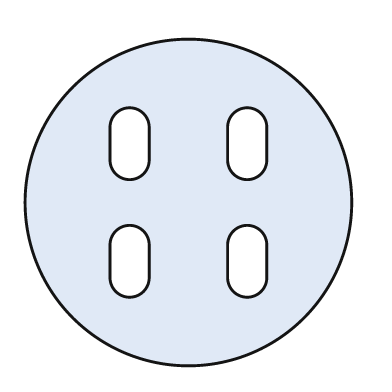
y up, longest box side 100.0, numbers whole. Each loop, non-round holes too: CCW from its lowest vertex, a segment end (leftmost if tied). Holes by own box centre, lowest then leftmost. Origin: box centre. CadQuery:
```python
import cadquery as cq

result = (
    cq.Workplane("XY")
    .moveTo(0.0, 0.0)
    .circle(50.0)
    .moveTo(-24.0, -23.0)
    .threePointArc((-18.0, -29.0), (-12.0, -23.0))
    .lineTo(-12.0, -13.0)
    .threePointArc((-18.0, -7.0), (-24.0, -13.0))
    .close()
    .moveTo(12.0, -23.0)
    .threePointArc((18.0, -29.0), (24.0, -23.0))
    .lineTo(24.0, -13.0)
    .threePointArc((18.0, -7.0), (12.0, -13.0))
    .close()
    .moveTo(-24.0, 13.0)
    .threePointArc((-18.0, 7.0), (-12.0, 13.0))
    .lineTo(-12.0, 23.0)
    .threePointArc((-18.0, 29.0), (-24.0, 23.0))
    .close()
    .moveTo(12.0, 13.0)
    .threePointArc((18.0, 7.0), (24.0, 13.0))
    .lineTo(24.0, 23.0)
    .threePointArc((18.0, 29.0), (12.0, 23.0))
    .close()
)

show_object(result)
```